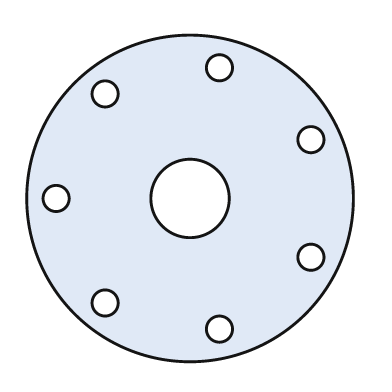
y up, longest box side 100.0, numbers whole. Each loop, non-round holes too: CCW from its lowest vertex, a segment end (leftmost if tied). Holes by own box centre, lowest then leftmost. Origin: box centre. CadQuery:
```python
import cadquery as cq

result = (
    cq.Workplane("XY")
    .moveTo(0.0, 0.0)
    .circle(50.0)
    .moveTo(9.0, -40.0)
    .circle(4.0)
    .moveTo(-26.0, -32.0)
    .circle(4.0)
    .moveTo(37.0, -18.0)
    .circle(4.0)
    .moveTo(-41.0, 0.0)
    .circle(4.0)
    .moveTo(0.0, 0.0)
    .circle(12.0)
    .moveTo(37.0, 18.0)
    .circle(4.0)
    .moveTo(-26.0, 32.0)
    .circle(4.0)
    .moveTo(9.0, 40.0)
    .circle(4.0)
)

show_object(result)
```